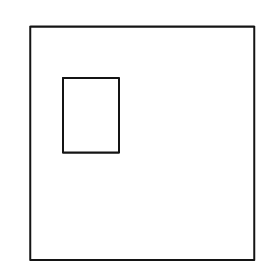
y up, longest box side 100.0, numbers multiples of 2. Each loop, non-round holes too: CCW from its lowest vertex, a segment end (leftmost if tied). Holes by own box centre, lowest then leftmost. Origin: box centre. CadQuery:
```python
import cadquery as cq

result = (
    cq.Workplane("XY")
    .moveTo(-48.0, -50.0)
    .lineTo(48.0, -50.0)
    .lineTo(48.0, 50.0)
    .lineTo(-48.0, 50.0)
    .close()
    .moveTo(-34.0, -4.0)
    .lineTo(-10.0, -4.0)
    .lineTo(-10.0, 28.0)
    .lineTo(-34.0, 28.0)
    .close()
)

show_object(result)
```